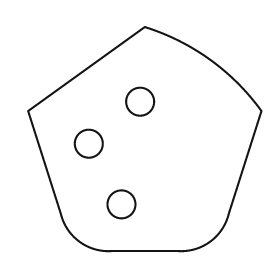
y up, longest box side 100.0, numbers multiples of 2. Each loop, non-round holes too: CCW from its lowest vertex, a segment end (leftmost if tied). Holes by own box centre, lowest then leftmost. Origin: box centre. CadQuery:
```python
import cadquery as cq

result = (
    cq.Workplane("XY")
    .moveTo(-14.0, -48.0)
    .lineTo(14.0, -48.0)
    .threePointArc((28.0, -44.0), (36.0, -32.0))
    .lineTo(50.0, 12.0)
    .threePointArc((28.0, 34.0), (0.0, 48.0))
    .lineTo(-50.0, 12.0)
    .lineTo(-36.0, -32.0)
    .threePointArc((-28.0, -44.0), (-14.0, -48.0))
    .close()
    .moveTo(-10.0, -28.0)
    .circle(6.0)
    .moveTo(-24.0, -2.0)
    .circle(6.0)
    .moveTo(-2.0, 16.0)
    .circle(6.0)
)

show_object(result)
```